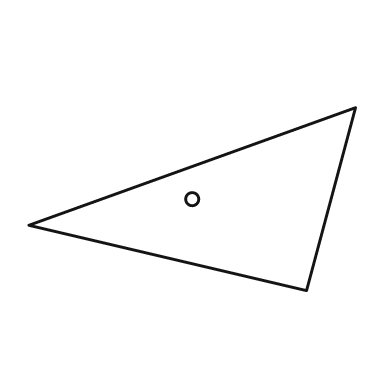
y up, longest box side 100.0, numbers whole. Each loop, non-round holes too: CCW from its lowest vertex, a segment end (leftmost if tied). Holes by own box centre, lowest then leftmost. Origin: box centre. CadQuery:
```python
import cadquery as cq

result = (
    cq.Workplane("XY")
    .moveTo(35.0, -28.0)
    .lineTo(50.0, 28.0)
    .lineTo(-50.0, -8.0)
    .close()
    .moveTo(0.0, 0.0)
    .circle(2.0)
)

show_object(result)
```